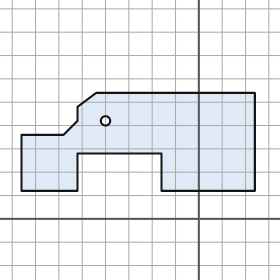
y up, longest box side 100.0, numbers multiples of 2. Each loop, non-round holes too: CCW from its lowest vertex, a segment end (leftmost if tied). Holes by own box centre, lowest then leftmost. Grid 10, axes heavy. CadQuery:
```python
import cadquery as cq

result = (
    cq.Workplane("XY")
    .moveTo(-76.0, 12.0)
    .lineTo(-52.0, 12.0)
    .lineTo(-52.0, 28.0)
    .lineTo(-16.0, 28.0)
    .lineTo(-16.0, 12.0)
    .lineTo(24.0, 12.0)
    .lineTo(24.0, 54.0)
    .lineTo(-44.0, 54.0)
    .lineTo(-52.0, 48.0)
    .lineTo(-52.0, 42.0)
    .lineTo(-58.0, 36.0)
    .lineTo(-76.0, 36.0)
    .close()
    .moveTo(-40.0, 42.0)
    .circle(2.0)
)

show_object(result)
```